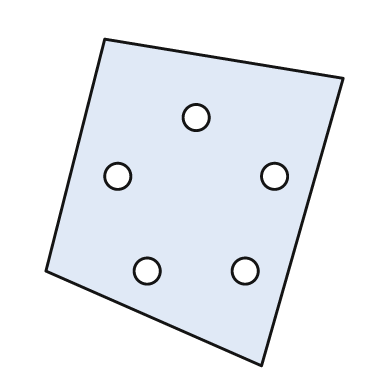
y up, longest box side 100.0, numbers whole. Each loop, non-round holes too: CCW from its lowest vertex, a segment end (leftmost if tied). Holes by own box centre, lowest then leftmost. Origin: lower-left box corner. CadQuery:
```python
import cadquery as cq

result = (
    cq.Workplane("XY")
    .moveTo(66.0, 0.0)
    .lineTo(91.0, 88.0)
    .lineTo(18.0, 100.0)
    .lineTo(0.0, 29.0)
    .close()
    .moveTo(31.0, 29.0)
    .circle(4.0)
    .moveTo(61.0, 29.0)
    .circle(4.0)
    .moveTo(22.0, 58.0)
    .circle(4.0)
    .moveTo(70.0, 58.0)
    .circle(4.0)
    .moveTo(46.0, 76.0)
    .circle(4.0)
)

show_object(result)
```